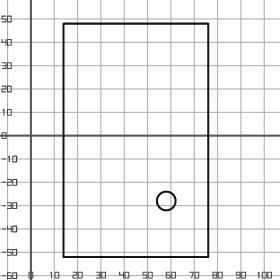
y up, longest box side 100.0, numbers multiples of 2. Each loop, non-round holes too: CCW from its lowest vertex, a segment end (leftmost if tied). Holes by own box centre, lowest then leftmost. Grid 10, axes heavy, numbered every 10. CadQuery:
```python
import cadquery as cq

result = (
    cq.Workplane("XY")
    .moveTo(14.0, -52.0)
    .lineTo(76.0, -52.0)
    .lineTo(76.0, 48.0)
    .lineTo(14.0, 48.0)
    .close()
    .moveTo(58.0, -28.0)
    .circle(4.0)
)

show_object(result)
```